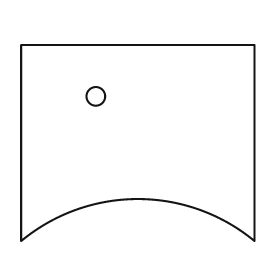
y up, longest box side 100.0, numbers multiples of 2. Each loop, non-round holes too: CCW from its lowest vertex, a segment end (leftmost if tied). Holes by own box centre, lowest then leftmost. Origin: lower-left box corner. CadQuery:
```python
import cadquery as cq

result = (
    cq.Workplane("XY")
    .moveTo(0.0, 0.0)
    .threePointArc((50.0, 18.0), (100.0, 0.0))
    .lineTo(100.0, 84.0)
    .lineTo(0.0, 84.0)
    .close()
    .moveTo(32.0, 62.0)
    .circle(4.0)
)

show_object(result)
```